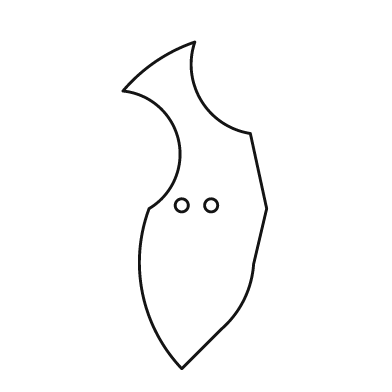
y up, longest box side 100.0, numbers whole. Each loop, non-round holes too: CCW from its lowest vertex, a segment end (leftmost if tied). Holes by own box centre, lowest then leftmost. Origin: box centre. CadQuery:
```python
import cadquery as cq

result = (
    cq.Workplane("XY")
    .moveTo(-4.0, -50.0)
    .lineTo(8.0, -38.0)
    .threePointArc((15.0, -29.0), (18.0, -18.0))
    .lineTo(22.0, -1.0)
    .lineTo(17.0, 22.0)
    .threePointArc((2.0, 32.0), (0.0, 50.0))
    .threePointArc((-12.0, 44.0), (-22.0, 35.0))
    .threePointArc((-5.0, 20.0), (-14.0, -1.0))
    .threePointArc((-16.0, -27.0), (-4.0, -50.0))
    .close()
    .moveTo(-4.0, 0.0)
    .circle(2.0)
    .moveTo(5.0, 0.0)
    .circle(2.0)
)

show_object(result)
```